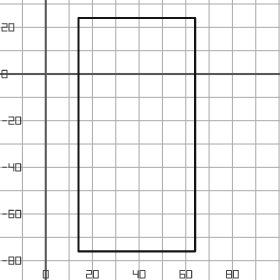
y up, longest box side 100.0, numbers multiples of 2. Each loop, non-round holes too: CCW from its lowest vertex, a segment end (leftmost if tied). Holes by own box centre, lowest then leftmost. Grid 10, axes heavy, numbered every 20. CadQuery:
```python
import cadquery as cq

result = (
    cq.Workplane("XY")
    .moveTo(14.0, -76.0)
    .lineTo(64.0, -76.0)
    .lineTo(64.0, 24.0)
    .lineTo(14.0, 24.0)
    .close()
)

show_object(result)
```